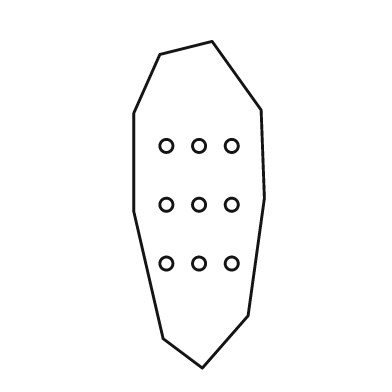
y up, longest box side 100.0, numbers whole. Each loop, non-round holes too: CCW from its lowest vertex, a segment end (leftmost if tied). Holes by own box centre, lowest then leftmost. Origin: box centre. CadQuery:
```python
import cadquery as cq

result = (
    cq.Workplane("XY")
    .moveTo(1.0, -50.0)
    .lineTo(15.0, -34.0)
    .lineTo(20.0, 2.0)
    .lineTo(19.0, 29.0)
    .lineTo(4.0, 50.0)
    .lineTo(-12.0, 46.0)
    .lineTo(-20.0, 28.0)
    .lineTo(-20.0, -2.0)
    .lineTo(-11.0, -41.0)
    .close()
    .moveTo(-10.0, -18.0)
    .circle(2.0)
    .moveTo(0.0, -18.0)
    .circle(2.0)
    .moveTo(10.0, -18.0)
    .circle(2.0)
    .moveTo(-10.0, 0.0)
    .circle(2.0)
    .moveTo(0.0, 0.0)
    .circle(2.0)
    .moveTo(10.0, 0.0)
    .circle(2.0)
    .moveTo(-10.0, 18.0)
    .circle(2.0)
    .moveTo(0.0, 18.0)
    .circle(2.0)
    .moveTo(10.0, 18.0)
    .circle(2.0)
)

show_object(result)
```